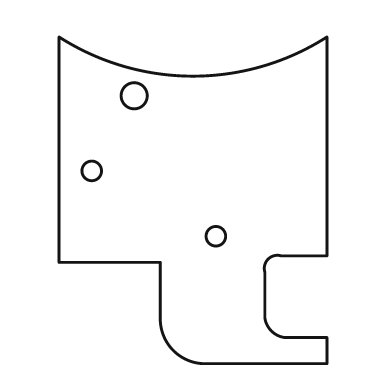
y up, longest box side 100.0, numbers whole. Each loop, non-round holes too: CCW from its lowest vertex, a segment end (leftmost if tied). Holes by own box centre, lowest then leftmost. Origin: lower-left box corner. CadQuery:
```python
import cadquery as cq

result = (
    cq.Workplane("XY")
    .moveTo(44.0, 0.0)
    .lineTo(82.0, 0.0)
    .lineTo(82.0, 8.0)
    .lineTo(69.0, 8.0)
    .threePointArc((65.0, 10.0), (63.0, 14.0))
    .lineTo(63.0, 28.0)
    .threePointArc((64.0, 32.0), (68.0, 33.0))
    .lineTo(82.0, 33.0)
    .lineTo(82.0, 100.0)
    .threePointArc((41.0, 88.0), (0.0, 100.0))
    .lineTo(0.0, 31.0)
    .lineTo(31.0, 31.0)
    .lineTo(31.0, 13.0)
    .threePointArc((35.0, 4.0), (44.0, 0.0))
    .close()
    .moveTo(48.0, 39.0)
    .circle(3.0)
    .moveTo(10.0, 59.0)
    .circle(3.0)
    .moveTo(23.0, 82.0)
    .circle(4.0)
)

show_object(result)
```